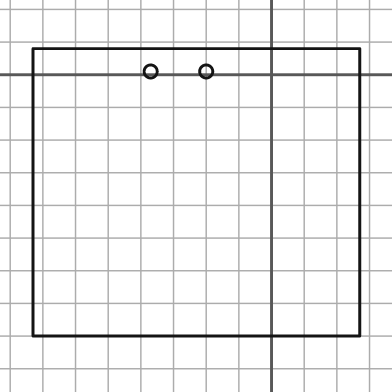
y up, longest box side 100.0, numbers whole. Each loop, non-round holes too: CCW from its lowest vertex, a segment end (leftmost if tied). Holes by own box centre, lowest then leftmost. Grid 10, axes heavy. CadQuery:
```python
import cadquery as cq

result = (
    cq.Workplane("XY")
    .moveTo(-73.0, -80.0)
    .lineTo(27.0, -80.0)
    .lineTo(27.0, 8.0)
    .lineTo(-73.0, 8.0)
    .close()
    .moveTo(-37.0, 1.0)
    .circle(2.0)
    .moveTo(-20.0, 1.0)
    .circle(2.0)
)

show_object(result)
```